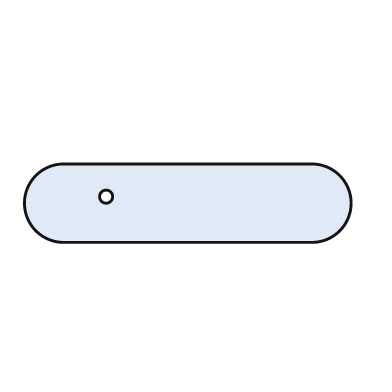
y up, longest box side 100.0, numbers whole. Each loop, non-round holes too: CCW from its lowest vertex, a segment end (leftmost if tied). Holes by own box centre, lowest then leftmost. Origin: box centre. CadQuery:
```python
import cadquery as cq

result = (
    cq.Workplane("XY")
    .moveTo(-38.0, -12.0)
    .lineTo(38.0, -12.0)
    .threePointArc((50.0, 0.0), (38.0, 12.0))
    .lineTo(-38.0, 12.0)
    .threePointArc((-50.0, 0.0), (-38.0, -12.0))
    .close()
    .moveTo(-25.0, 2.0)
    .circle(2.0)
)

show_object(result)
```